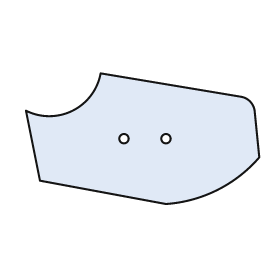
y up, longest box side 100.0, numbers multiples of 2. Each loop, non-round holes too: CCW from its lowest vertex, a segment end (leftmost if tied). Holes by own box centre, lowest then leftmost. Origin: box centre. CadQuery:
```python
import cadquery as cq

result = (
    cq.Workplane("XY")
    .moveTo(10.0, -28.0)
    .threePointArc((32.0, -22.0), (50.0, -8.0))
    .lineTo(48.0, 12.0)
    .threePointArc((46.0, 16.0), (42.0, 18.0))
    .lineTo(-18.0, 28.0)
    .threePointArc((-30.0, 12.0), (-50.0, 12.0))
    .lineTo(-44.0, -18.0)
    .close()
    .moveTo(-8.0, 0.0)
    .circle(2.0)
    .moveTo(10.0, 0.0)
    .circle(2.0)
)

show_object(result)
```